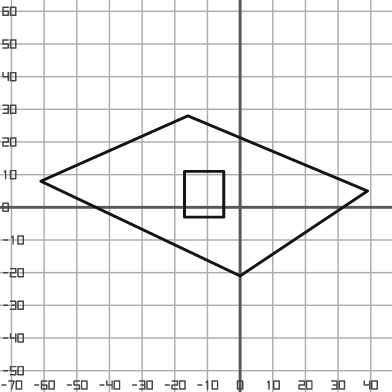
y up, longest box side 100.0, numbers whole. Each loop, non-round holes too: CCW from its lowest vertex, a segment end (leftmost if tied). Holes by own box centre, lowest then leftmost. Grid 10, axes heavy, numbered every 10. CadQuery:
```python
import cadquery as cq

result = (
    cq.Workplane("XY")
    .moveTo(0.0, -21.0)
    .lineTo(39.0, 5.0)
    .lineTo(-16.0, 28.0)
    .lineTo(-61.0, 8.0)
    .close()
    .moveTo(-17.0, -3.0)
    .lineTo(-5.0, -3.0)
    .lineTo(-5.0, 11.0)
    .lineTo(-17.0, 11.0)
    .close()
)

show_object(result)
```